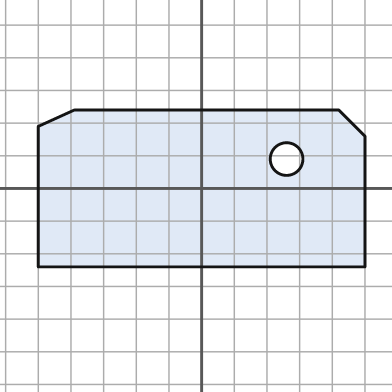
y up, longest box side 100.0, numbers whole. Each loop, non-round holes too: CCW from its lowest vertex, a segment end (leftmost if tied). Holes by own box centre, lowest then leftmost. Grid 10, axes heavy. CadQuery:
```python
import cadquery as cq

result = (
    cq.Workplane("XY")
    .moveTo(-50.0, -24.0)
    .lineTo(50.0, -24.0)
    .lineTo(50.0, 16.0)
    .lineTo(42.0, 24.0)
    .lineTo(-39.0, 24.0)
    .lineTo(-50.0, 19.0)
    .close()
    .moveTo(26.0, 9.0)
    .circle(5.0)
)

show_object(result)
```